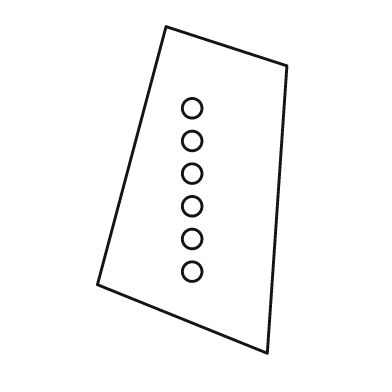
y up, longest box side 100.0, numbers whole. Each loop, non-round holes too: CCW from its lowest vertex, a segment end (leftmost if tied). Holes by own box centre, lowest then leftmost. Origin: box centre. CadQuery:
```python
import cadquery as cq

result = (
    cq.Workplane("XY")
    .moveTo(23.0, -50.0)
    .lineTo(29.0, 38.0)
    .lineTo(-8.0, 50.0)
    .lineTo(-29.0, -29.0)
    .close()
    .moveTo(0.0, -25.0)
    .circle(3.0)
    .moveTo(0.0, -15.0)
    .circle(3.0)
    .moveTo(0.0, -5.0)
    .circle(3.0)
    .moveTo(0.0, 5.0)
    .circle(3.0)
    .moveTo(0.0, 15.0)
    .circle(3.0)
    .moveTo(0.0, 25.0)
    .circle(3.0)
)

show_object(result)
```